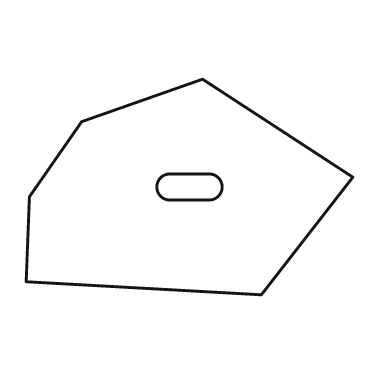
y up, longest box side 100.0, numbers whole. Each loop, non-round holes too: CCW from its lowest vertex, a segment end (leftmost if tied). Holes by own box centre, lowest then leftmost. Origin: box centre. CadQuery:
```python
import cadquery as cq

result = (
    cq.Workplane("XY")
    .moveTo(22.0, -33.0)
    .lineTo(50.0, 3.0)
    .lineTo(4.0, 33.0)
    .lineTo(-33.0, 20.0)
    .lineTo(-49.0, -3.0)
    .lineTo(-50.0, -29.0)
    .close()
    .moveTo(-6.0, -4.0)
    .lineTo(6.0, -4.0)
    .threePointArc((10.0, 0.0), (6.0, 4.0))
    .lineTo(-6.0, 4.0)
    .threePointArc((-10.0, 0.0), (-6.0, -4.0))
    .close()
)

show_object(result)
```